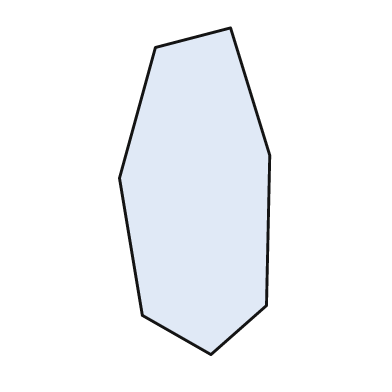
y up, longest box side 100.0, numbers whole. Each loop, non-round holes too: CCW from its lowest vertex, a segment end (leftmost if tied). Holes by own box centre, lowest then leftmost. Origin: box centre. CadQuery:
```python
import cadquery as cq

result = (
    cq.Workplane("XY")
    .moveTo(5.0, -50.0)
    .lineTo(22.0, -35.0)
    .lineTo(23.0, 11.0)
    .lineTo(11.0, 50.0)
    .lineTo(-12.0, 44.0)
    .lineTo(-23.0, 4.0)
    .lineTo(-16.0, -38.0)
    .close()
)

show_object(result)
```